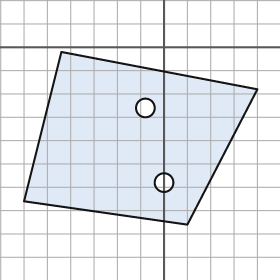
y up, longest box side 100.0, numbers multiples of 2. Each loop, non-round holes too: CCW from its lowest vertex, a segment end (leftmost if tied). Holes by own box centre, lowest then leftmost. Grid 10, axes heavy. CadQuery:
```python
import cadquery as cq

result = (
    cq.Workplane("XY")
    .moveTo(10.0, -76.0)
    .lineTo(40.0, -18.0)
    .lineTo(-44.0, -2.0)
    .lineTo(-60.0, -66.0)
    .close()
    .moveTo(0.0, -58.0)
    .circle(4.0)
    .moveTo(-8.0, -26.0)
    .circle(4.0)
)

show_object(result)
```